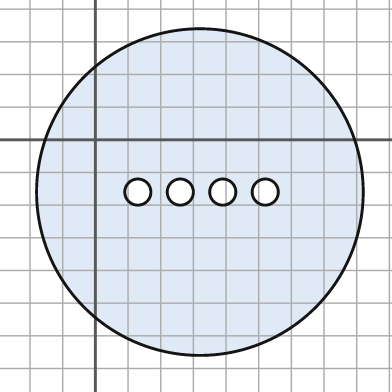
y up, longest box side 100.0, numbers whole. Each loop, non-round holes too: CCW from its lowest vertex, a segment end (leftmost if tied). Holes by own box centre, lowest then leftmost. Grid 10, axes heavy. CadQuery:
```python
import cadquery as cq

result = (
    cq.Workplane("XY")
    .moveTo(32.0, -16.0)
    .circle(50.0)
    .moveTo(13.0, -16.0)
    .circle(4.0)
    .moveTo(26.0, -16.0)
    .circle(4.0)
    .moveTo(39.0, -16.0)
    .circle(4.0)
    .moveTo(52.0, -16.0)
    .circle(4.0)
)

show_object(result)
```